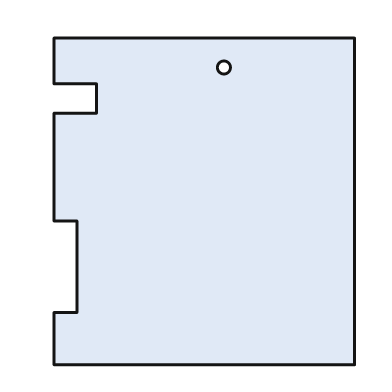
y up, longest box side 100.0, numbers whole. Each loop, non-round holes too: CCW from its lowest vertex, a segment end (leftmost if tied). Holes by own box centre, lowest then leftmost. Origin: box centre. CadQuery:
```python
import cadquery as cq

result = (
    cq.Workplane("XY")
    .moveTo(-46.0, -50.0)
    .lineTo(46.0, -50.0)
    .lineTo(46.0, 50.0)
    .lineTo(-46.0, 50.0)
    .lineTo(-46.0, 36.0)
    .lineTo(-33.0, 36.0)
    .lineTo(-33.0, 27.0)
    .lineTo(-46.0, 27.0)
    .lineTo(-46.0, -6.0)
    .lineTo(-39.0, -6.0)
    .lineTo(-39.0, -34.0)
    .lineTo(-46.0, -34.0)
    .close()
    .moveTo(6.0, 41.0)
    .circle(2.0)
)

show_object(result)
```